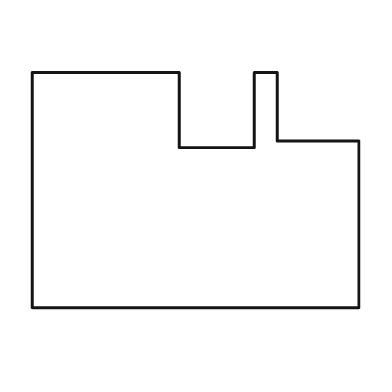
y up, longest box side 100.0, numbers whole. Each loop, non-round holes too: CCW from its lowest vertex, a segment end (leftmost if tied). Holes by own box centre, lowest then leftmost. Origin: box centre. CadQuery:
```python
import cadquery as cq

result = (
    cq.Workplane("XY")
    .moveTo(-50.0, -36.0)
    .lineTo(50.0, -36.0)
    .lineTo(50.0, 15.0)
    .lineTo(25.0, 15.0)
    .lineTo(25.0, 36.0)
    .lineTo(18.0, 36.0)
    .lineTo(18.0, 13.0)
    .lineTo(-5.0, 13.0)
    .lineTo(-5.0, 36.0)
    .lineTo(-50.0, 36.0)
    .close()
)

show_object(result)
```